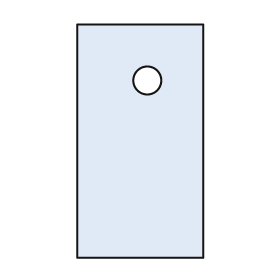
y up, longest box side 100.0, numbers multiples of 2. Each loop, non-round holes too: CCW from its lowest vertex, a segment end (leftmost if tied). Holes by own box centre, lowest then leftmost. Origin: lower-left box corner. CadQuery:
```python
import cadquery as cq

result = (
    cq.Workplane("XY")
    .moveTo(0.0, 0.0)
    .lineTo(54.0, 0.0)
    .lineTo(54.0, 100.0)
    .lineTo(0.0, 100.0)
    .close()
    .moveTo(30.0, 76.0)
    .circle(6.0)
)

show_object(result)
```